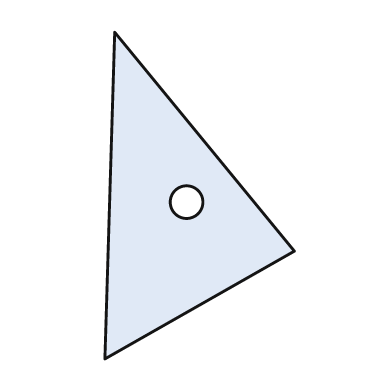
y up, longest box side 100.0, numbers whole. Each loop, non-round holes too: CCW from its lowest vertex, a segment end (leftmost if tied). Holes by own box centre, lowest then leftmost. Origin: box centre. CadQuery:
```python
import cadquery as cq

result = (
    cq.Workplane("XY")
    .moveTo(-29.0, -50.0)
    .lineTo(29.0, -17.0)
    .lineTo(-26.0, 50.0)
    .close()
    .moveTo(-4.0, -2.0)
    .circle(5.0)
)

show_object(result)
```